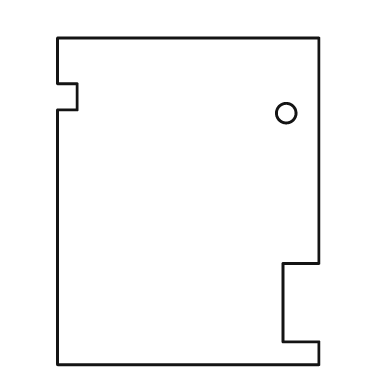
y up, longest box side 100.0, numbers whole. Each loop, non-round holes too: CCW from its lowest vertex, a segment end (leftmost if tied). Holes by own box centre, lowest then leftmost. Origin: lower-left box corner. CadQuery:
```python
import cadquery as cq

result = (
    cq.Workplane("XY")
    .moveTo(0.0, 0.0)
    .lineTo(80.0, 0.0)
    .lineTo(80.0, 7.0)
    .lineTo(69.0, 7.0)
    .lineTo(69.0, 31.0)
    .lineTo(80.0, 31.0)
    .lineTo(80.0, 100.0)
    .lineTo(0.0, 100.0)
    .lineTo(0.0, 86.0)
    .lineTo(6.0, 86.0)
    .lineTo(6.0, 78.0)
    .lineTo(0.0, 78.0)
    .close()
    .moveTo(70.0, 77.0)
    .circle(3.0)
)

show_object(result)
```